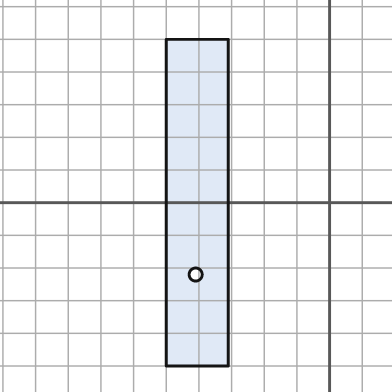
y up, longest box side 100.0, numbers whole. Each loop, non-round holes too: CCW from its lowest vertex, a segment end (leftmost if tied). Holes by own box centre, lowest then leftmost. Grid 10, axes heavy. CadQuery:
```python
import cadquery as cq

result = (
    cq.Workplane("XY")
    .moveTo(-50.0, -50.0)
    .lineTo(-31.0, -50.0)
    .lineTo(-31.0, 50.0)
    .lineTo(-50.0, 50.0)
    .close()
    .moveTo(-41.0, -22.0)
    .circle(2.0)
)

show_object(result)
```